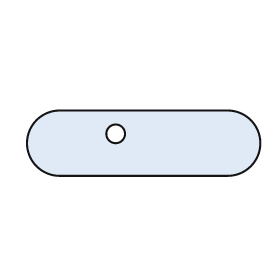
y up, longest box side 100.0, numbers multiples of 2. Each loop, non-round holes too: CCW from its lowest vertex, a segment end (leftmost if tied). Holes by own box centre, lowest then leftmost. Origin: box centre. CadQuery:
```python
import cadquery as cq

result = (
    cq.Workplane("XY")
    .moveTo(-36.0, -14.0)
    .lineTo(36.0, -14.0)
    .threePointArc((50.0, 0.0), (36.0, 14.0))
    .lineTo(-36.0, 14.0)
    .threePointArc((-50.0, 0.0), (-36.0, -14.0))
    .close()
    .moveTo(-12.0, 4.0)
    .circle(4.0)
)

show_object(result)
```